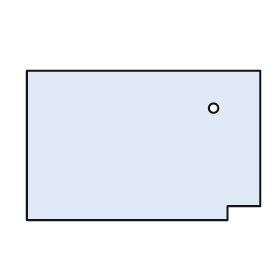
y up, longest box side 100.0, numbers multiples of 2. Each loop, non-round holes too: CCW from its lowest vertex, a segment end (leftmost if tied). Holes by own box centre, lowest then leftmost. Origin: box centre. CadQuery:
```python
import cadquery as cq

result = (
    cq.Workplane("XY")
    .moveTo(-50.0, -32.0)
    .lineTo(36.0, -32.0)
    .lineTo(36.0, -26.0)
    .lineTo(50.0, -26.0)
    .lineTo(50.0, 32.0)
    .lineTo(-50.0, 32.0)
    .close()
    .moveTo(30.0, 16.0)
    .circle(2.0)
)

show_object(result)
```